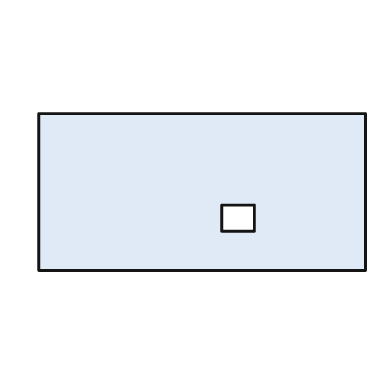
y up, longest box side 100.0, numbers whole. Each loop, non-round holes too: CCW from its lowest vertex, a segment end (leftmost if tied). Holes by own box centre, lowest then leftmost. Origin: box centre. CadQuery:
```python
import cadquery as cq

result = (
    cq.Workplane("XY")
    .moveTo(-50.0, -24.0)
    .lineTo(50.0, -24.0)
    .lineTo(50.0, 24.0)
    .lineTo(-50.0, 24.0)
    .close()
    .moveTo(6.0, -12.0)
    .lineTo(16.0, -12.0)
    .lineTo(16.0, -4.0)
    .lineTo(6.0, -4.0)
    .close()
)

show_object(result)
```